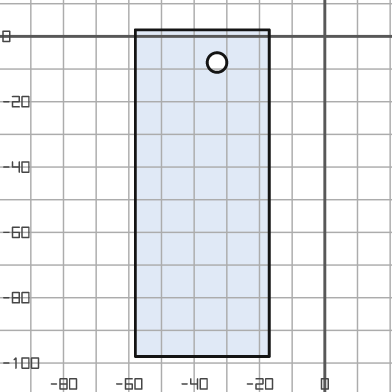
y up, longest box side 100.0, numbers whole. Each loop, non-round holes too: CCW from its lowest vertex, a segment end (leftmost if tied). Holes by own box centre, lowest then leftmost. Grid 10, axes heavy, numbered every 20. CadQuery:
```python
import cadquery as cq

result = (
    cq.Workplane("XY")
    .moveTo(-58.0, -98.0)
    .lineTo(-17.0, -98.0)
    .lineTo(-17.0, 2.0)
    .lineTo(-58.0, 2.0)
    .close()
    .moveTo(-33.0, -8.0)
    .circle(3.0)
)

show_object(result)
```